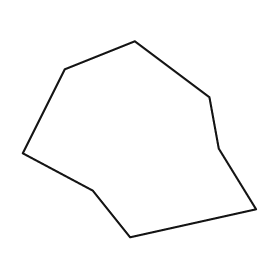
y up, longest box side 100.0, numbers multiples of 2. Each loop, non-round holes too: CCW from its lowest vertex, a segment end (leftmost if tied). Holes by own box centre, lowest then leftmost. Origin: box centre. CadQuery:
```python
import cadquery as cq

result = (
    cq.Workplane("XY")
    .moveTo(-4.0, -42.0)
    .lineTo(50.0, -30.0)
    .lineTo(34.0, -4.0)
    .lineTo(30.0, 18.0)
    .lineTo(-2.0, 42.0)
    .lineTo(-32.0, 30.0)
    .lineTo(-50.0, -6.0)
    .lineTo(-20.0, -22.0)
    .close()
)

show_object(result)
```